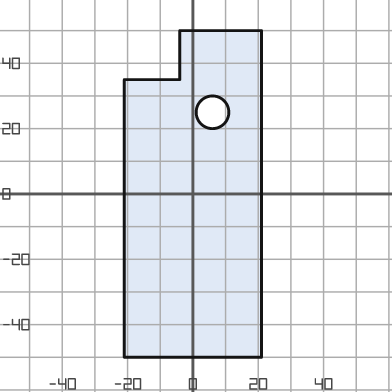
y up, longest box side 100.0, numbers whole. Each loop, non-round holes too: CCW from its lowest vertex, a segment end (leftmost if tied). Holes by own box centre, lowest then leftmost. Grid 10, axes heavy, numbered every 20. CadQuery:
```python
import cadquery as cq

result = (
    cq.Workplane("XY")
    .moveTo(-21.0, -50.0)
    .lineTo(21.0, -50.0)
    .lineTo(21.0, 50.0)
    .lineTo(-4.0, 50.0)
    .lineTo(-4.0, 35.0)
    .lineTo(-21.0, 35.0)
    .close()
    .moveTo(6.0, 25.0)
    .circle(5.0)
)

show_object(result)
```